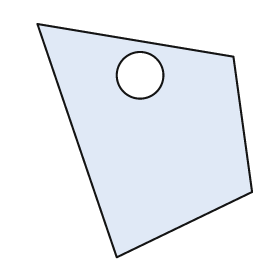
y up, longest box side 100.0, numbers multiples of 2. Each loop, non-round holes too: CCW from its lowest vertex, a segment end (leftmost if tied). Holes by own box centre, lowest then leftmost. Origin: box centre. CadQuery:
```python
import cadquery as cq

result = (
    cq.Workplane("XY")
    .moveTo(-12.0, -50.0)
    .lineTo(46.0, -22.0)
    .lineTo(38.0, 36.0)
    .lineTo(-46.0, 50.0)
    .close()
    .moveTo(-2.0, 28.0)
    .circle(10.0)
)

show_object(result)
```